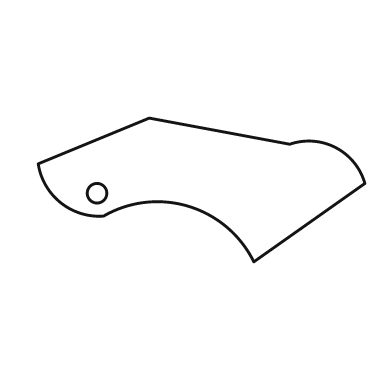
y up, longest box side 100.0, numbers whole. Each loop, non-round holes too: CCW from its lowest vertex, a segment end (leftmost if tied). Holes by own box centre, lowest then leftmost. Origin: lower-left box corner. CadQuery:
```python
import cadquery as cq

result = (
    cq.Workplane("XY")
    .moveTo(66.0, 0.0)
    .lineTo(100.0, 24.0)
    .threePointArc((91.0, 35.0), (77.0, 36.0))
    .lineTo(34.0, 44.0)
    .lineTo(0.0, 30.0)
    .threePointArc((7.0, 18.0), (20.0, 14.0))
    .threePointArc((46.0, 17.0), (66.0, 0.0))
    .close()
    .moveTo(18.0, 21.0)
    .circle(3.0)
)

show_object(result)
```